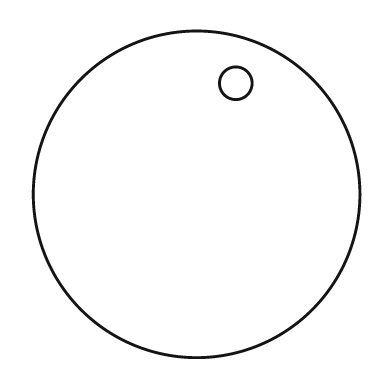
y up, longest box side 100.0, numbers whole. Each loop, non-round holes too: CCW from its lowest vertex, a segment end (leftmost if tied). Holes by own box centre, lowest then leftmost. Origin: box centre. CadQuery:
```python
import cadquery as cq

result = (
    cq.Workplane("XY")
    .moveTo(0.0, 0.0)
    .circle(50.0)
    .moveTo(12.0, 34.0)
    .circle(5.0)
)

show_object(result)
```